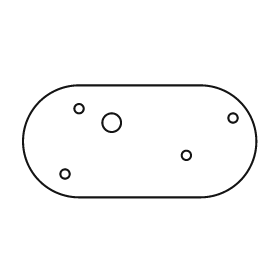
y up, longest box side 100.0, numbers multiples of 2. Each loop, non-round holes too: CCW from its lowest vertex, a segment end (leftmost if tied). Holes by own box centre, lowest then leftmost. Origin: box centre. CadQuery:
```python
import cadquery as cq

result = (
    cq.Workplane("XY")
    .moveTo(-26.0, -24.0)
    .lineTo(26.0, -24.0)
    .threePointArc((50.0, 0.0), (26.0, 24.0))
    .lineTo(-26.0, 24.0)
    .threePointArc((-50.0, 0.0), (-26.0, -24.0))
    .close()
    .moveTo(-32.0, -14.0)
    .circle(2.0)
    .moveTo(20.0, -6.0)
    .circle(2.0)
    .moveTo(-12.0, 8.0)
    .circle(4.0)
    .moveTo(40.0, 10.0)
    .circle(2.0)
    .moveTo(-26.0, 14.0)
    .circle(2.0)
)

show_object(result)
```